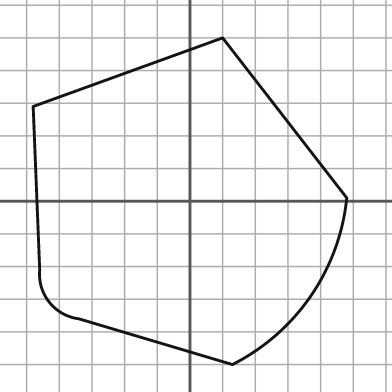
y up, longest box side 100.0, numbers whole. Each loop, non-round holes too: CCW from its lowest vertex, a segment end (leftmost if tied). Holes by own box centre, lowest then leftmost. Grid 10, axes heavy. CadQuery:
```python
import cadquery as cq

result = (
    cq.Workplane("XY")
    .moveTo(13.0, -50.0)
    .threePointArc((37.0, -29.0), (48.0, 1.0))
    .lineTo(10.0, 50.0)
    .lineTo(-48.0, 29.0)
    .lineTo(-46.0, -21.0)
    .threePointArc((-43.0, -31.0), (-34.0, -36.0))
    .close()
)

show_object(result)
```